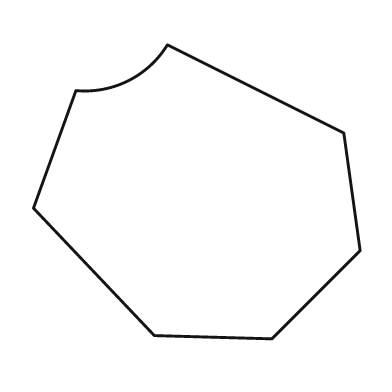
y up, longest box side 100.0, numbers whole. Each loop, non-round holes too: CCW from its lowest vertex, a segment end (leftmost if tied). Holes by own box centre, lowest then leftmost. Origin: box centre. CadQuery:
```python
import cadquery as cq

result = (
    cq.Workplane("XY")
    .moveTo(23.0, -45.0)
    .lineTo(50.0, -18.0)
    .lineTo(45.0, 18.0)
    .lineTo(-9.0, 45.0)
    .threePointArc((-21.0, 34.0), (-37.0, 31.0))
    .lineTo(-50.0, -5.0)
    .lineTo(-13.0, -44.0)
    .close()
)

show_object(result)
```